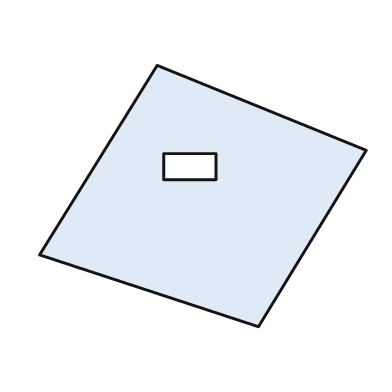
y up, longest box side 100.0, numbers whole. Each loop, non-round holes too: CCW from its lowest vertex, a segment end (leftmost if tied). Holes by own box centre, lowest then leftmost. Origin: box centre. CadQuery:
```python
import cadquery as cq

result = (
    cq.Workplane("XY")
    .moveTo(17.0, -40.0)
    .lineTo(50.0, 14.0)
    .lineTo(-14.0, 40.0)
    .lineTo(-50.0, -18.0)
    .close()
    .moveTo(-12.0, 5.0)
    .lineTo(4.0, 5.0)
    .lineTo(4.0, 13.0)
    .lineTo(-12.0, 13.0)
    .close()
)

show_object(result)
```